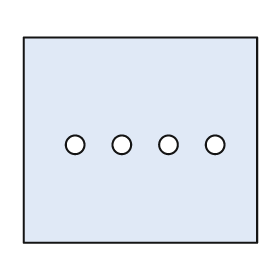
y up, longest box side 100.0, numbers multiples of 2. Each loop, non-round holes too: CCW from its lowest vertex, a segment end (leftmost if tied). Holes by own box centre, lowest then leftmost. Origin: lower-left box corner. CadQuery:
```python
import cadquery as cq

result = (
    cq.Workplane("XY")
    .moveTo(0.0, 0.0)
    .lineTo(100.0, 0.0)
    .lineTo(100.0, 88.0)
    .lineTo(0.0, 88.0)
    .close()
    .moveTo(22.0, 42.0)
    .circle(4.0)
    .moveTo(42.0, 42.0)
    .circle(4.0)
    .moveTo(62.0, 42.0)
    .circle(4.0)
    .moveTo(82.0, 42.0)
    .circle(4.0)
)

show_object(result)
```